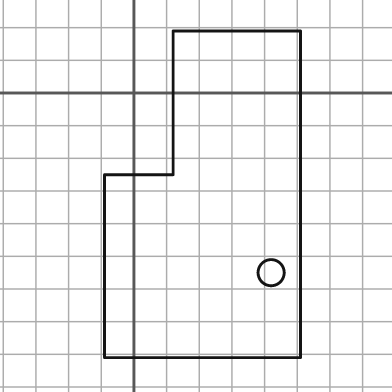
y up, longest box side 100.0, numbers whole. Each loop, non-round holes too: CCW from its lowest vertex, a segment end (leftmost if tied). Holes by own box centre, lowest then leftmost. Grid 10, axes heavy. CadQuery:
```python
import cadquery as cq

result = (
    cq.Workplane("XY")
    .moveTo(-9.0, -81.0)
    .lineTo(51.0, -81.0)
    .lineTo(51.0, 19.0)
    .lineTo(12.0, 19.0)
    .lineTo(12.0, -25.0)
    .lineTo(-9.0, -25.0)
    .close()
    .moveTo(42.0, -55.0)
    .circle(4.0)
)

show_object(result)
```